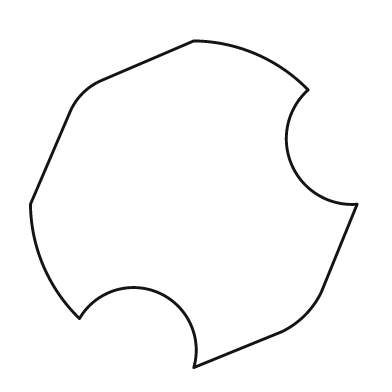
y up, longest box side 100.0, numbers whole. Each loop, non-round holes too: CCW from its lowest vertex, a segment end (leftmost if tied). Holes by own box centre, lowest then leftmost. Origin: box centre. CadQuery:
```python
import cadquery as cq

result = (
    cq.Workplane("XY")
    .moveTo(0.0, -50.0)
    .lineTo(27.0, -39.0)
    .threePointArc((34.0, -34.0), (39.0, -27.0))
    .lineTo(50.0, 0.0)
    .threePointArc((30.0, 12.0), (35.0, 35.0))
    .threePointArc((19.0, 46.0), (0.0, 50.0))
    .lineTo(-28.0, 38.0)
    .threePointArc((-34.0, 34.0), (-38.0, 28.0))
    .lineTo(-50.0, 0.0)
    .threePointArc((-46.0, -19.0), (-35.0, -35.0))
    .threePointArc((-11.0, -27.0), (0.0, -50.0))
    .close()
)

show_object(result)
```